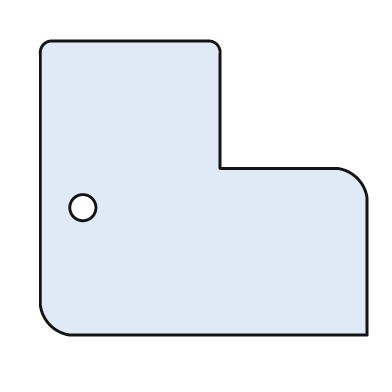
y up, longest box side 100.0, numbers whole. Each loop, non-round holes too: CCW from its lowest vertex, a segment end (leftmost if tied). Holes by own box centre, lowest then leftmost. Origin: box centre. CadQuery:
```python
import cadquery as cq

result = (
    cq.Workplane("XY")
    .moveTo(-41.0, -45.0)
    .lineTo(50.0, -45.0)
    .lineTo(50.0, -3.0)
    .threePointArc((47.0, 3.0), (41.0, 6.0))
    .lineTo(5.0, 6.0)
    .lineTo(5.0, 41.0)
    .threePointArc((4.0, 44.0), (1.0, 45.0))
    .lineTo(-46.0, 45.0)
    .threePointArc((-49.0, 44.0), (-50.0, 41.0))
    .lineTo(-50.0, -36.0)
    .threePointArc((-47.0, -42.0), (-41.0, -45.0))
    .close()
    .moveTo(-37.0, -6.0)
    .circle(4.0)
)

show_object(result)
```